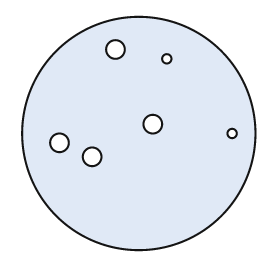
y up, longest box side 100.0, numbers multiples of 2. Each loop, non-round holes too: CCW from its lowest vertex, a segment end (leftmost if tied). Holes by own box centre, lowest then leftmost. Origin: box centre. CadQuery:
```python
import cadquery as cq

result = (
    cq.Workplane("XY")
    .moveTo(0.0, 0.0)
    .circle(50.0)
    .moveTo(-20.0, -10.0)
    .circle(4.0)
    .moveTo(-34.0, -4.0)
    .circle(4.0)
    .moveTo(40.0, 0.0)
    .circle(2.0)
    .moveTo(6.0, 4.0)
    .circle(4.0)
    .moveTo(12.0, 32.0)
    .circle(2.0)
    .moveTo(-10.0, 36.0)
    .circle(4.0)
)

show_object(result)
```